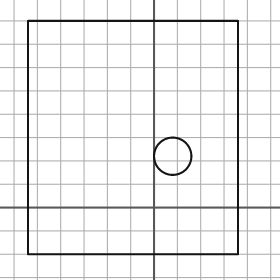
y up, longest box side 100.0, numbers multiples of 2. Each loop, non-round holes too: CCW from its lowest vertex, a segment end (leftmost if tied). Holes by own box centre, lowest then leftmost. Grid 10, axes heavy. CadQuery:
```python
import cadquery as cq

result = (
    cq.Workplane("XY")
    .moveTo(-54.0, -20.0)
    .lineTo(36.0, -20.0)
    .lineTo(36.0, 80.0)
    .lineTo(-54.0, 80.0)
    .close()
    .moveTo(8.0, 22.0)
    .circle(8.0)
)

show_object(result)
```